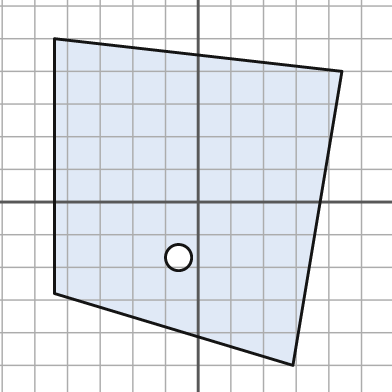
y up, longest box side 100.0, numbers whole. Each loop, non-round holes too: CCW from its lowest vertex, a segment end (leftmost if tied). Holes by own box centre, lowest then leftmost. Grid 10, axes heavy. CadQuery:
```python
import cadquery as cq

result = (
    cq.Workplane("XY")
    .moveTo(29.0, -50.0)
    .lineTo(44.0, 40.0)
    .lineTo(-44.0, 50.0)
    .lineTo(-44.0, -28.0)
    .close()
    .moveTo(-6.0, -17.0)
    .circle(4.0)
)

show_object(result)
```